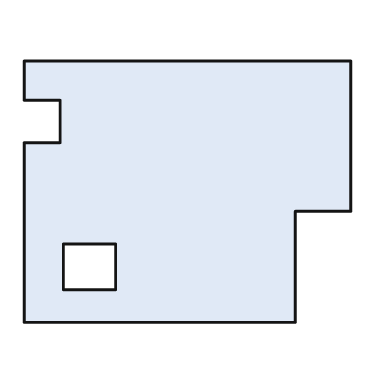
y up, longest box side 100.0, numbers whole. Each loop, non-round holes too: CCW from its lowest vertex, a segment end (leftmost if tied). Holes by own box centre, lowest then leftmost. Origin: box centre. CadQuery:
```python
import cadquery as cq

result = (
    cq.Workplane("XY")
    .moveTo(-50.0, -40.0)
    .lineTo(33.0, -40.0)
    .lineTo(33.0, -6.0)
    .lineTo(50.0, -6.0)
    .lineTo(50.0, 40.0)
    .lineTo(-50.0, 40.0)
    .lineTo(-50.0, 28.0)
    .lineTo(-39.0, 28.0)
    .lineTo(-39.0, 15.0)
    .lineTo(-50.0, 15.0)
    .close()
    .moveTo(-38.0, -30.0)
    .lineTo(-22.0, -30.0)
    .lineTo(-22.0, -16.0)
    .lineTo(-38.0, -16.0)
    .close()
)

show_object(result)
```